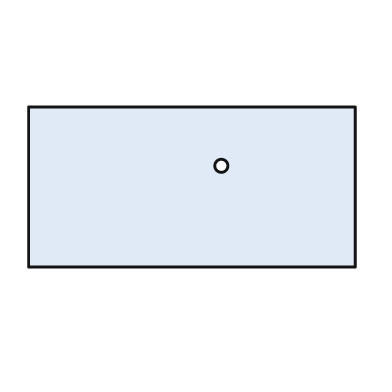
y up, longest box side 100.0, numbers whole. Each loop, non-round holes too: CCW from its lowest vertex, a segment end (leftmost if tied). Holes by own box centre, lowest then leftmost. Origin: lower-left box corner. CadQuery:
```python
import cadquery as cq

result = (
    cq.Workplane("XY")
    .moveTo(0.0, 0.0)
    .lineTo(100.0, 0.0)
    .lineTo(100.0, 49.0)
    .lineTo(0.0, 49.0)
    .close()
    .moveTo(59.0, 31.0)
    .circle(2.0)
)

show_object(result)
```